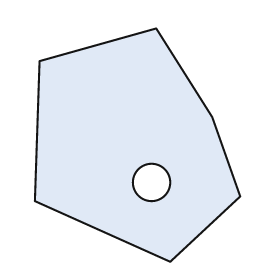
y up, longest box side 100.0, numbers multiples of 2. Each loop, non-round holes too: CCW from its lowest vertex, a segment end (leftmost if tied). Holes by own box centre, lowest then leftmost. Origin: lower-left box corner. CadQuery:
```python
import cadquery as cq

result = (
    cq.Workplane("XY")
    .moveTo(58.0, 0.0)
    .lineTo(88.0, 28.0)
    .lineTo(76.0, 62.0)
    .lineTo(52.0, 100.0)
    .lineTo(2.0, 86.0)
    .lineTo(0.0, 26.0)
    .close()
    .moveTo(50.0, 34.0)
    .circle(8.0)
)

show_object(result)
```